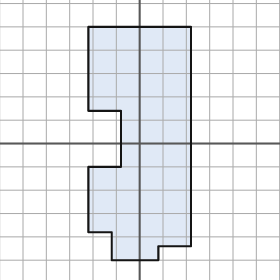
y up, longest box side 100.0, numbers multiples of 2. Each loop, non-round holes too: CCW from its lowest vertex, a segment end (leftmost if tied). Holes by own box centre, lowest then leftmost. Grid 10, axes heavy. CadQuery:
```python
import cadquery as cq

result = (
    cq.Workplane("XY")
    .moveTo(-12.0, -50.0)
    .lineTo(8.0, -50.0)
    .lineTo(8.0, -44.0)
    .lineTo(22.0, -44.0)
    .lineTo(22.0, 50.0)
    .lineTo(-22.0, 50.0)
    .lineTo(-22.0, 14.0)
    .lineTo(-8.0, 14.0)
    .lineTo(-8.0, -10.0)
    .lineTo(-22.0, -10.0)
    .lineTo(-22.0, -38.0)
    .lineTo(-12.0, -38.0)
    .close()
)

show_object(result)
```